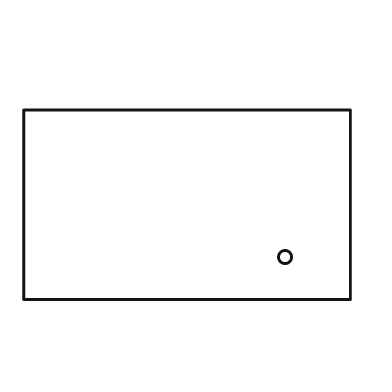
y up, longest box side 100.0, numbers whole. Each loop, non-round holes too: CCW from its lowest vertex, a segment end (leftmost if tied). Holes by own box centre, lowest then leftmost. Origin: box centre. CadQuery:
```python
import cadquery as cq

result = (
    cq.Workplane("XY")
    .moveTo(-50.0, -29.0)
    .lineTo(50.0, -29.0)
    .lineTo(50.0, 29.0)
    .lineTo(-50.0, 29.0)
    .close()
    .moveTo(30.0, -16.0)
    .circle(2.0)
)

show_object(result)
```